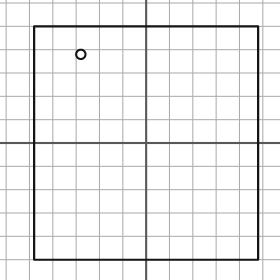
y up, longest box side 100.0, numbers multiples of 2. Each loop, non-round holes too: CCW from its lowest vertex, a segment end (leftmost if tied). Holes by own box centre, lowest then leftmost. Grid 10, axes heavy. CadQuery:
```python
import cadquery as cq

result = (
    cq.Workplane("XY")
    .moveTo(-48.0, -50.0)
    .lineTo(48.0, -50.0)
    .lineTo(48.0, 50.0)
    .lineTo(-48.0, 50.0)
    .close()
    .moveTo(-28.0, 38.0)
    .circle(2.0)
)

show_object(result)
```